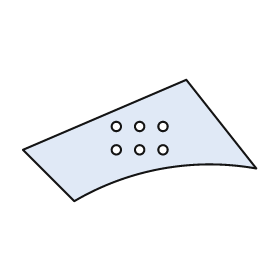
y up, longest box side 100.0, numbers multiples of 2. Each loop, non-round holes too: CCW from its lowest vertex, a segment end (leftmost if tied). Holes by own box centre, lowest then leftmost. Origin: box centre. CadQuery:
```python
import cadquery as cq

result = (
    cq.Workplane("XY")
    .moveTo(-28.0, -26.0)
    .threePointArc((10.0, -12.0), (50.0, -12.0))
    .lineTo(20.0, 26.0)
    .lineTo(-50.0, -4.0)
    .close()
    .moveTo(-10.0, -4.0)
    .circle(2.0)
    .moveTo(0.0, -4.0)
    .circle(2.0)
    .moveTo(10.0, -4.0)
    .circle(2.0)
    .moveTo(-10.0, 6.0)
    .circle(2.0)
    .moveTo(0.0, 6.0)
    .circle(2.0)
    .moveTo(10.0, 6.0)
    .circle(2.0)
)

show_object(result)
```